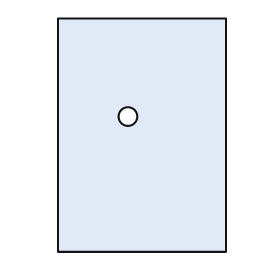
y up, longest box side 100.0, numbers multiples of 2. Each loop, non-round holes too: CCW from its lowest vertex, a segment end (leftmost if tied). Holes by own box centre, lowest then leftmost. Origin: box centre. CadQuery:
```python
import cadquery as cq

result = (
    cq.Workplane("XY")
    .moveTo(-36.0, -50.0)
    .lineTo(36.0, -50.0)
    .lineTo(36.0, 50.0)
    .lineTo(-36.0, 50.0)
    .close()
    .moveTo(-6.0, 8.0)
    .circle(4.0)
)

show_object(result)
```